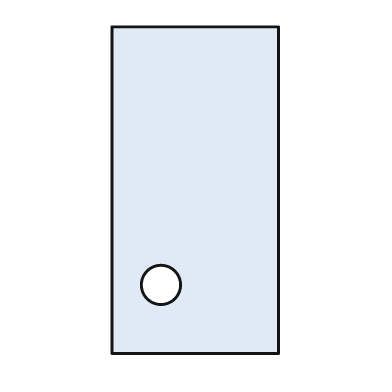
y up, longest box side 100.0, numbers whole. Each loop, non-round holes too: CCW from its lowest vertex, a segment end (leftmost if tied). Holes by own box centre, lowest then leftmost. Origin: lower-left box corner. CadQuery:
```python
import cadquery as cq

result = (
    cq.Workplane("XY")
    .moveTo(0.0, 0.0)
    .lineTo(51.0, 0.0)
    .lineTo(51.0, 100.0)
    .lineTo(0.0, 100.0)
    .close()
    .moveTo(15.0, 21.0)
    .circle(6.0)
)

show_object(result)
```